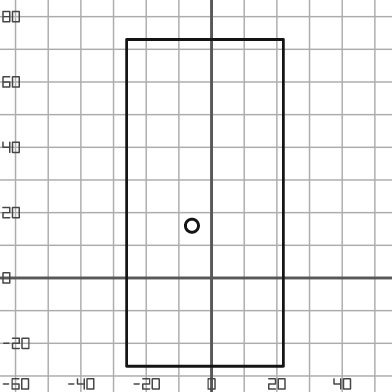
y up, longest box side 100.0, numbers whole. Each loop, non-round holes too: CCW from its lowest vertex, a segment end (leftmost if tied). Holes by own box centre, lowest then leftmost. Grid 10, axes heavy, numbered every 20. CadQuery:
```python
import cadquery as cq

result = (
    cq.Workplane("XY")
    .moveTo(-26.0, -27.0)
    .lineTo(22.0, -27.0)
    .lineTo(22.0, 73.0)
    .lineTo(-26.0, 73.0)
    .close()
    .moveTo(-6.0, 16.0)
    .circle(2.0)
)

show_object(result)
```